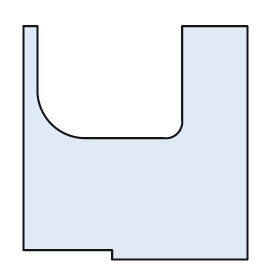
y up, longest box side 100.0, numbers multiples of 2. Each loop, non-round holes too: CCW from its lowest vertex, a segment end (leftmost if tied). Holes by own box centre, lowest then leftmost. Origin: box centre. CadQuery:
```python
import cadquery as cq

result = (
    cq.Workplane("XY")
    .moveTo(-10.0, -50.0)
    .lineTo(48.0, -50.0)
    .lineTo(48.0, 50.0)
    .lineTo(20.0, 50.0)
    .lineTo(20.0, 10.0)
    .threePointArc((18.0, 4.0), (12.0, 2.0))
    .lineTo(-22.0, 2.0)
    .threePointArc((-36.0, 8.0), (-42.0, 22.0))
    .lineTo(-42.0, 50.0)
    .lineTo(-48.0, 50.0)
    .lineTo(-48.0, -46.0)
    .lineTo(-10.0, -46.0)
    .close()
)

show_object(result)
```